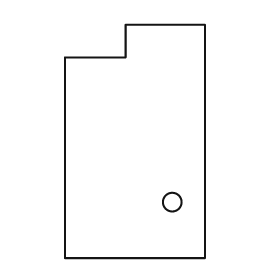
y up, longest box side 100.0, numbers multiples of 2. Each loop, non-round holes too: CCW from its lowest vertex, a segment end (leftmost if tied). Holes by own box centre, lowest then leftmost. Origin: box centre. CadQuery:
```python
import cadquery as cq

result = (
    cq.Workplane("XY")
    .moveTo(-30.0, -50.0)
    .lineTo(30.0, -50.0)
    .lineTo(30.0, 50.0)
    .lineTo(-4.0, 50.0)
    .lineTo(-4.0, 36.0)
    .lineTo(-30.0, 36.0)
    .close()
    .moveTo(16.0, -26.0)
    .circle(4.0)
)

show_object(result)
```